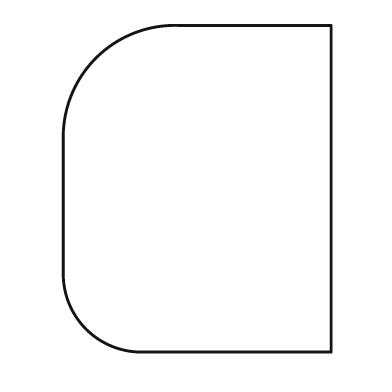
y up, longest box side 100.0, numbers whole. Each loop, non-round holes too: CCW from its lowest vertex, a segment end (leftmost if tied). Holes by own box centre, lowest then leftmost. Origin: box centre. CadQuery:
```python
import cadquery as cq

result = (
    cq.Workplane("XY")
    .moveTo(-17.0, -50.0)
    .lineTo(41.0, -50.0)
    .lineTo(41.0, 50.0)
    .lineTo(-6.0, 50.0)
    .threePointArc((-31.0, 40.0), (-41.0, 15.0))
    .lineTo(-41.0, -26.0)
    .threePointArc((-34.0, -43.0), (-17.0, -50.0))
    .close()
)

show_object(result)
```